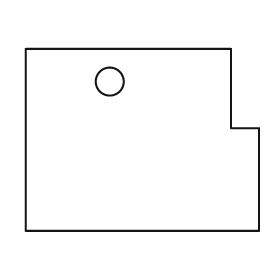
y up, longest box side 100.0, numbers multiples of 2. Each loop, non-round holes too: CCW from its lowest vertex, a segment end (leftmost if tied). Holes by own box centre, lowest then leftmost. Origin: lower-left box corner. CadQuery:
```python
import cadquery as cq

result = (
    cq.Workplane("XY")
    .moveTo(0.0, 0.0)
    .lineTo(100.0, 0.0)
    .lineTo(100.0, 44.0)
    .lineTo(88.0, 44.0)
    .lineTo(88.0, 78.0)
    .lineTo(0.0, 78.0)
    .close()
    .moveTo(36.0, 64.0)
    .circle(6.0)
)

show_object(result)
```